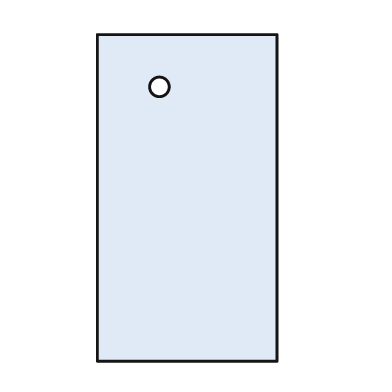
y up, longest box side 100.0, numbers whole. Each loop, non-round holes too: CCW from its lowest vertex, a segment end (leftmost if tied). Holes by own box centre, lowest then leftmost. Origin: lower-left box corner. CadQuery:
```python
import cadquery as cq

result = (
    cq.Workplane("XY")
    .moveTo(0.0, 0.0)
    .lineTo(55.0, 0.0)
    .lineTo(55.0, 100.0)
    .lineTo(0.0, 100.0)
    .close()
    .moveTo(19.0, 84.0)
    .circle(3.0)
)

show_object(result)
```